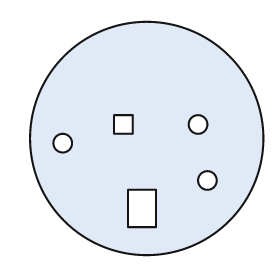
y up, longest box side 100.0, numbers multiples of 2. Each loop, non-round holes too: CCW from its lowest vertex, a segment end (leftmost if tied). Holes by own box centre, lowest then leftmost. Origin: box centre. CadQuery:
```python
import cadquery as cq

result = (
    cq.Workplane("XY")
    .moveTo(0.0, 0.0)
    .circle(50.0)
    .moveTo(-8.0, -38.0)
    .lineTo(4.0, -38.0)
    .lineTo(4.0, -22.0)
    .lineTo(-8.0, -22.0)
    .close()
    .moveTo(26.0, -18.0)
    .circle(4.0)
    .moveTo(-36.0, -2.0)
    .circle(4.0)
    .moveTo(-14.0, 2.0)
    .lineTo(-6.0, 2.0)
    .lineTo(-6.0, 10.0)
    .lineTo(-14.0, 10.0)
    .close()
    .moveTo(22.0, 6.0)
    .circle(4.0)
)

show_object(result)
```